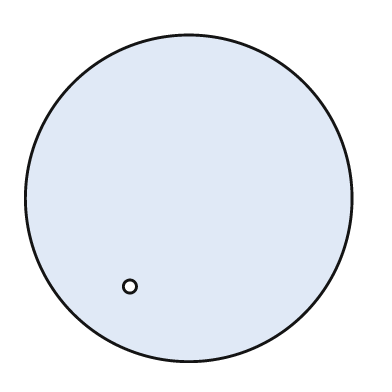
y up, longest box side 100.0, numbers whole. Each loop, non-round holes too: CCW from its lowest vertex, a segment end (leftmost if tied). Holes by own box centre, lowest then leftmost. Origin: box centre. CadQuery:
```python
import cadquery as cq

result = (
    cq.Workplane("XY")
    .moveTo(0.0, 0.0)
    .circle(50.0)
    .moveTo(-18.0, -27.0)
    .circle(2.0)
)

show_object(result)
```